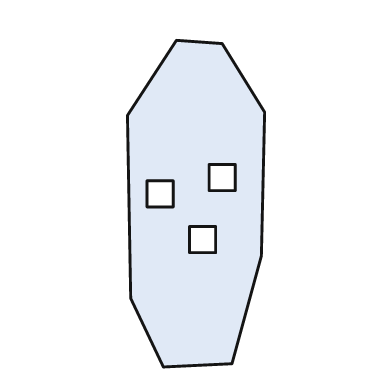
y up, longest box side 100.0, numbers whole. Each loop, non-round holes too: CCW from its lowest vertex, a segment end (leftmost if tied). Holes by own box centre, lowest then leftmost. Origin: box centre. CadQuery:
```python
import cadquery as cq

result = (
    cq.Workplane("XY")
    .moveTo(-10.0, -50.0)
    .lineTo(11.0, -49.0)
    .lineTo(20.0, -16.0)
    .lineTo(21.0, 28.0)
    .lineTo(8.0, 49.0)
    .lineTo(-6.0, 50.0)
    .lineTo(-21.0, 27.0)
    .lineTo(-20.0, -29.0)
    .close()
    .moveTo(-2.0, -15.0)
    .lineTo(6.0, -15.0)
    .lineTo(6.0, -7.0)
    .lineTo(-2.0, -7.0)
    .close()
    .moveTo(-15.0, -1.0)
    .lineTo(-7.0, -1.0)
    .lineTo(-7.0, 7.0)
    .lineTo(-15.0, 7.0)
    .close()
    .moveTo(4.0, 4.0)
    .lineTo(12.0, 4.0)
    .lineTo(12.0, 12.0)
    .lineTo(4.0, 12.0)
    .close()
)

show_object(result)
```